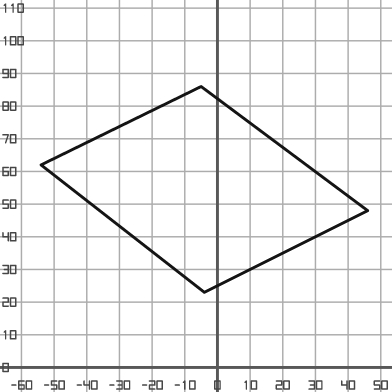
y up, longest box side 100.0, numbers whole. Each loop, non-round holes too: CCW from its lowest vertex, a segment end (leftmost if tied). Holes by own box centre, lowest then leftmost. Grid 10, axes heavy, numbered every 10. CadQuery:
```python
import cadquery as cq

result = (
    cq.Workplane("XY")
    .moveTo(-4.0, 23.0)
    .lineTo(46.0, 48.0)
    .lineTo(-5.0, 86.0)
    .lineTo(-54.0, 62.0)
    .close()
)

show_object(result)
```